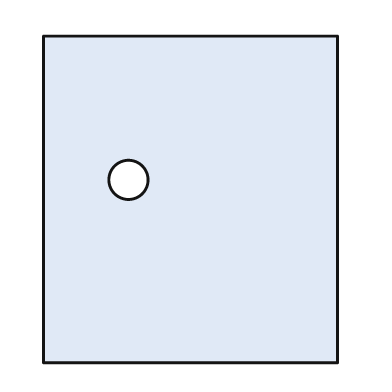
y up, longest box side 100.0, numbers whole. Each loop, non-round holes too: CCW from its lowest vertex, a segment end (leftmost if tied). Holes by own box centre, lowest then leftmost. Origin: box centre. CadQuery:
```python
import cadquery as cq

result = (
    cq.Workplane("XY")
    .moveTo(-45.0, -50.0)
    .lineTo(45.0, -50.0)
    .lineTo(45.0, 50.0)
    .lineTo(-45.0, 50.0)
    .close()
    .moveTo(-19.0, 6.0)
    .circle(6.0)
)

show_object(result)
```